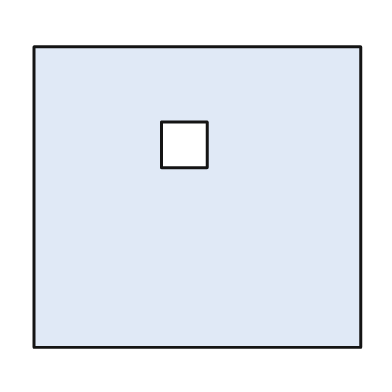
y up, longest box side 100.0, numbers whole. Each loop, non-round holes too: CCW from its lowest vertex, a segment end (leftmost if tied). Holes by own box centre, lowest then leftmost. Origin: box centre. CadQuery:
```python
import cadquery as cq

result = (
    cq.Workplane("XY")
    .moveTo(-50.0, -46.0)
    .lineTo(50.0, -46.0)
    .lineTo(50.0, 46.0)
    .lineTo(-50.0, 46.0)
    .close()
    .moveTo(-11.0, 9.0)
    .lineTo(3.0, 9.0)
    .lineTo(3.0, 23.0)
    .lineTo(-11.0, 23.0)
    .close()
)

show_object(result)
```